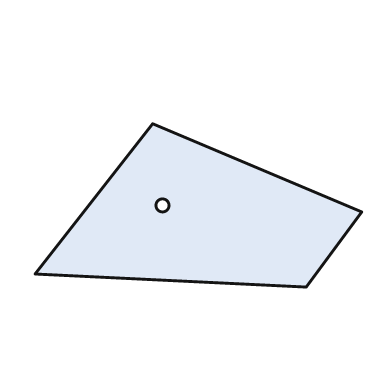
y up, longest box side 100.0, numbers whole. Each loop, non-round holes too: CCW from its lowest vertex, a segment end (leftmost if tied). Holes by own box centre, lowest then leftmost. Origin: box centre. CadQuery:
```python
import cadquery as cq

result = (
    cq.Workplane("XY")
    .moveTo(33.0, -25.0)
    .lineTo(50.0, -2.0)
    .lineTo(-14.0, 25.0)
    .lineTo(-50.0, -21.0)
    .close()
    .moveTo(-11.0, 0.0)
    .circle(2.0)
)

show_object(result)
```